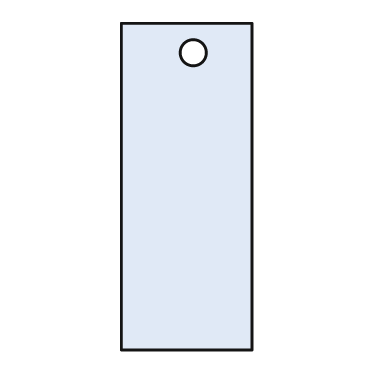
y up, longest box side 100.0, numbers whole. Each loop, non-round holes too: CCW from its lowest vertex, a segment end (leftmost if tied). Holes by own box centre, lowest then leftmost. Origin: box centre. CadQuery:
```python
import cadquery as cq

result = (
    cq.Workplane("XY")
    .moveTo(-20.0, -50.0)
    .lineTo(20.0, -50.0)
    .lineTo(20.0, 50.0)
    .lineTo(-20.0, 50.0)
    .close()
    .moveTo(2.0, 41.0)
    .circle(4.0)
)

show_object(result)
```